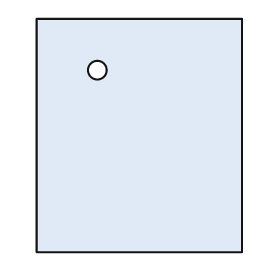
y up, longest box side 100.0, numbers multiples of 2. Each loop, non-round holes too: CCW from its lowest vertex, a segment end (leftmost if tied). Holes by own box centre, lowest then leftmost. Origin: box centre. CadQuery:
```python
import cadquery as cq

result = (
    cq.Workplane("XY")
    .moveTo(-44.0, -50.0)
    .lineTo(44.0, -50.0)
    .lineTo(44.0, 50.0)
    .lineTo(-44.0, 50.0)
    .close()
    .moveTo(-18.0, 28.0)
    .circle(4.0)
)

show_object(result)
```